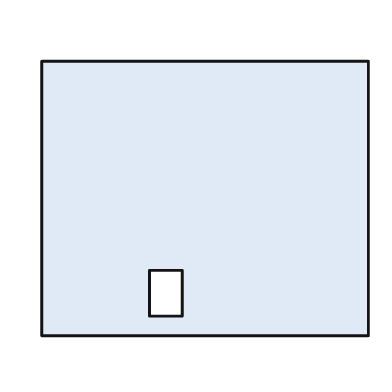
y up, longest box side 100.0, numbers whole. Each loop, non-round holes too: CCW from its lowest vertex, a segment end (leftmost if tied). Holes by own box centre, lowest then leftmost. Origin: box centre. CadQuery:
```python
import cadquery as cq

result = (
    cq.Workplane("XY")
    .moveTo(-50.0, -42.0)
    .lineTo(50.0, -42.0)
    .lineTo(50.0, 42.0)
    .lineTo(-50.0, 42.0)
    .close()
    .moveTo(-17.0, -36.0)
    .lineTo(-7.0, -36.0)
    .lineTo(-7.0, -22.0)
    .lineTo(-17.0, -22.0)
    .close()
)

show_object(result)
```